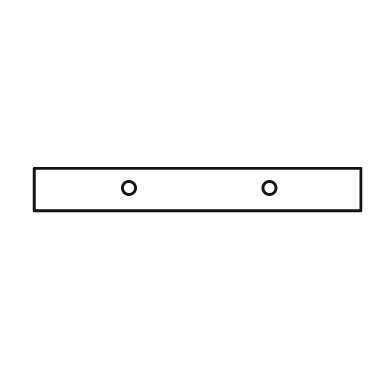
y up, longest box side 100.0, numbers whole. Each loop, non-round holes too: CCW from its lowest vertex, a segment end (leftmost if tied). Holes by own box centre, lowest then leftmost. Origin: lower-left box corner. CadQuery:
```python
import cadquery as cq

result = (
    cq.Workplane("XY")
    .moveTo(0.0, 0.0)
    .lineTo(100.0, 0.0)
    .lineTo(100.0, 13.0)
    .lineTo(0.0, 13.0)
    .close()
    .moveTo(29.0, 7.0)
    .circle(2.0)
    .moveTo(72.0, 7.0)
    .circle(2.0)
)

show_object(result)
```